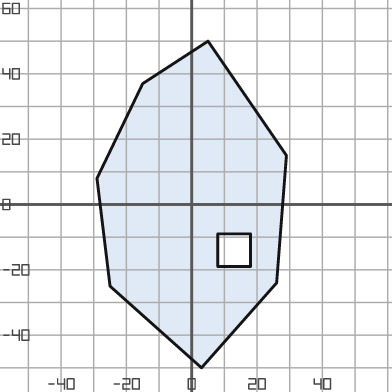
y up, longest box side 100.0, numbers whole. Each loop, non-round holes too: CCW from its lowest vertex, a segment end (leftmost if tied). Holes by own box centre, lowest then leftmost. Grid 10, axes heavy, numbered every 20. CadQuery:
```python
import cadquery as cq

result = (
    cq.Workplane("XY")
    .moveTo(3.0, -50.0)
    .lineTo(26.0, -24.0)
    .lineTo(29.0, 15.0)
    .lineTo(5.0, 50.0)
    .lineTo(-15.0, 37.0)
    .lineTo(-29.0, 8.0)
    .lineTo(-25.0, -25.0)
    .close()
    .moveTo(8.0, -19.0)
    .lineTo(18.0, -19.0)
    .lineTo(18.0, -9.0)
    .lineTo(8.0, -9.0)
    .close()
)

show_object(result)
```